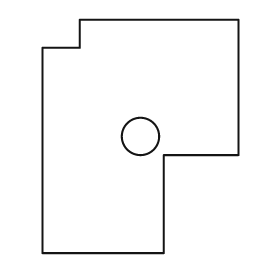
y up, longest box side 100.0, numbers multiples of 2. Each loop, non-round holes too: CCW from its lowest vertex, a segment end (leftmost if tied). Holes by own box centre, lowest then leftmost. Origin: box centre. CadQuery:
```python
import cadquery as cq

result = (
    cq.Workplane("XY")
    .moveTo(-42.0, -50.0)
    .lineTo(10.0, -50.0)
    .lineTo(10.0, -8.0)
    .lineTo(42.0, -8.0)
    .lineTo(42.0, 50.0)
    .lineTo(-26.0, 50.0)
    .lineTo(-26.0, 38.0)
    .lineTo(-42.0, 38.0)
    .close()
    .moveTo(0.0, 0.0)
    .circle(8.0)
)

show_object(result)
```